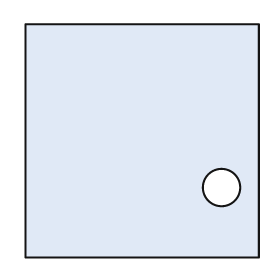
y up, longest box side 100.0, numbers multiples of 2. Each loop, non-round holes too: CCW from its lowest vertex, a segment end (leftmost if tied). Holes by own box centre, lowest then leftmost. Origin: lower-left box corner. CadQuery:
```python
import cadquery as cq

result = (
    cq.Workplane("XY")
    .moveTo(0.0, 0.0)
    .lineTo(100.0, 0.0)
    .lineTo(100.0, 100.0)
    .lineTo(0.0, 100.0)
    .close()
    .moveTo(84.0, 30.0)
    .circle(8.0)
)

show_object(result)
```